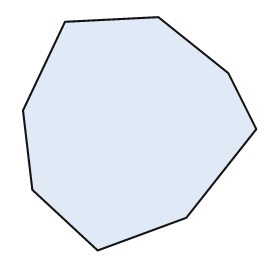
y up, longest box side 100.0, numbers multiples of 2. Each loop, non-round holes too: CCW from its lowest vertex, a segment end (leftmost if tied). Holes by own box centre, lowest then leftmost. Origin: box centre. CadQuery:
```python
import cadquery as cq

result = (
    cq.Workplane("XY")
    .moveTo(-18.0, -50.0)
    .lineTo(20.0, -36.0)
    .lineTo(50.0, 2.0)
    .lineTo(38.0, 26.0)
    .lineTo(8.0, 50.0)
    .lineTo(-32.0, 48.0)
    .lineTo(-50.0, 10.0)
    .lineTo(-46.0, -24.0)
    .close()
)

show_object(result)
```